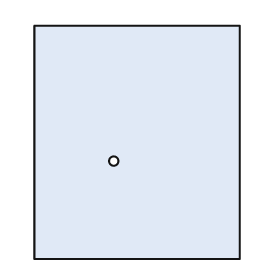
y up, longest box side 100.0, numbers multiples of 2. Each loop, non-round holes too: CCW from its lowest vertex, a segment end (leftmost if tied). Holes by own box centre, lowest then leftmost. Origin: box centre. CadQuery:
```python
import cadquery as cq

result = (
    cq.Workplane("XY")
    .moveTo(-44.0, -50.0)
    .lineTo(44.0, -50.0)
    .lineTo(44.0, 50.0)
    .lineTo(-44.0, 50.0)
    .close()
    .moveTo(-10.0, -8.0)
    .circle(2.0)
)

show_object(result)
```